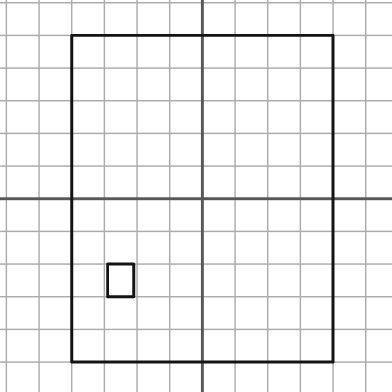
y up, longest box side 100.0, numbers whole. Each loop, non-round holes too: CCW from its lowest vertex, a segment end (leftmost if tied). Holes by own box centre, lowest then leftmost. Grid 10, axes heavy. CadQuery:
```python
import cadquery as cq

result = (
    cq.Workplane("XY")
    .moveTo(-40.0, -50.0)
    .lineTo(40.0, -50.0)
    .lineTo(40.0, 50.0)
    .lineTo(-40.0, 50.0)
    .close()
    .moveTo(-29.0, -30.0)
    .lineTo(-21.0, -30.0)
    .lineTo(-21.0, -20.0)
    .lineTo(-29.0, -20.0)
    .close()
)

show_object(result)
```